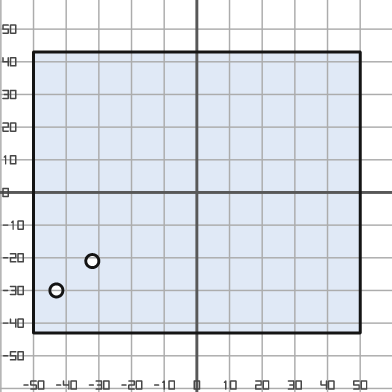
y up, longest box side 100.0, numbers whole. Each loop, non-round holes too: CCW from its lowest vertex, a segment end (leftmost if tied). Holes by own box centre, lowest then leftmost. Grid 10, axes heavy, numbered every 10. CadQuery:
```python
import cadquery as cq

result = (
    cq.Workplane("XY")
    .moveTo(-50.0, -43.0)
    .lineTo(50.0, -43.0)
    .lineTo(50.0, 43.0)
    .lineTo(-50.0, 43.0)
    .close()
    .moveTo(-43.0, -30.0)
    .circle(2.0)
    .moveTo(-32.0, -21.0)
    .circle(2.0)
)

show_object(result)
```